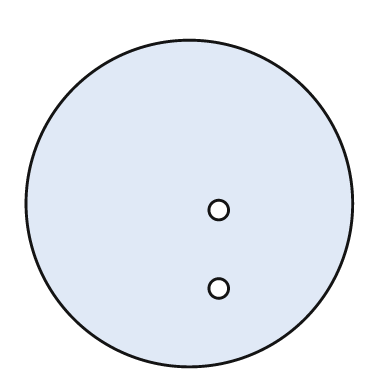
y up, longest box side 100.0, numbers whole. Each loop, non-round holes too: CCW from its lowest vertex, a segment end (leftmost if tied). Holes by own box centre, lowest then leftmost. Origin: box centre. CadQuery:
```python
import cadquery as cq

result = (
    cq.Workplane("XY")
    .moveTo(0.0, 0.0)
    .circle(50.0)
    .moveTo(9.0, -26.0)
    .circle(3.0)
    .moveTo(9.0, -2.0)
    .circle(3.0)
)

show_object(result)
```